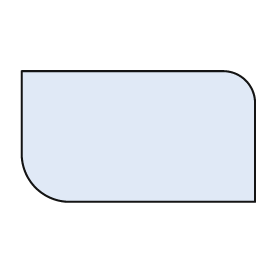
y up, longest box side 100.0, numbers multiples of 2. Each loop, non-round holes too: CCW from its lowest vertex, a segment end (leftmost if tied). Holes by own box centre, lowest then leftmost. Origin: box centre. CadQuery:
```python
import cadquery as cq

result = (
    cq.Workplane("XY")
    .moveTo(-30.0, -28.0)
    .lineTo(50.0, -28.0)
    .lineTo(50.0, 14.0)
    .threePointArc((46.0, 24.0), (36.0, 28.0))
    .lineTo(-50.0, 28.0)
    .lineTo(-50.0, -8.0)
    .threePointArc((-44.0, -22.0), (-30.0, -28.0))
    .close()
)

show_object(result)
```